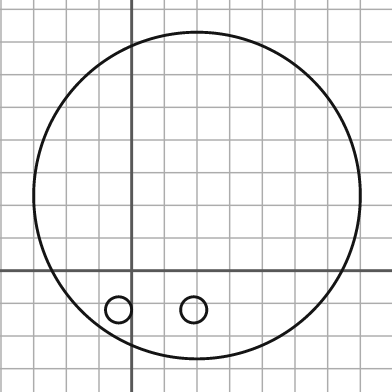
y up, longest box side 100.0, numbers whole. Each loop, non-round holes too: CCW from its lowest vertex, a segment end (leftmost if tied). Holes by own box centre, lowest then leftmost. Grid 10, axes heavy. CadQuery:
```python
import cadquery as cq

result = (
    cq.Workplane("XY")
    .moveTo(20.0, 23.0)
    .circle(50.0)
    .moveTo(-4.0, -12.0)
    .circle(4.0)
    .moveTo(19.0, -12.0)
    .circle(4.0)
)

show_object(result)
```